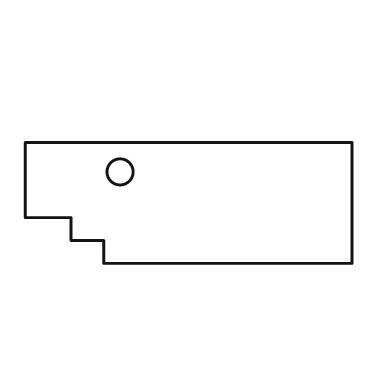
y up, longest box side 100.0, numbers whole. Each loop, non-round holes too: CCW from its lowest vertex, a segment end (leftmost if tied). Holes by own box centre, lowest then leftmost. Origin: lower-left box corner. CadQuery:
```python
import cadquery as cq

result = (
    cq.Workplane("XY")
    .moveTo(24.0, 0.0)
    .lineTo(100.0, 0.0)
    .lineTo(100.0, 37.0)
    .lineTo(0.0, 37.0)
    .lineTo(0.0, 14.0)
    .lineTo(14.0, 14.0)
    .lineTo(14.0, 7.0)
    .lineTo(24.0, 7.0)
    .close()
    .moveTo(29.0, 28.0)
    .circle(4.0)
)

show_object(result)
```